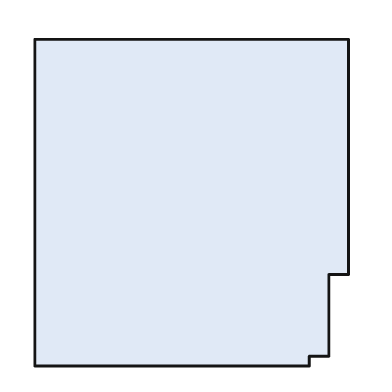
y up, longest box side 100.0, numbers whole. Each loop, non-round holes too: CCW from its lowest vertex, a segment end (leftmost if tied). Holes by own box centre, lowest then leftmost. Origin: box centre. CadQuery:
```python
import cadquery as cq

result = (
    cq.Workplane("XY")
    .moveTo(-48.0, -50.0)
    .lineTo(36.0, -50.0)
    .lineTo(36.0, -47.0)
    .lineTo(42.0, -47.0)
    .lineTo(42.0, -22.0)
    .lineTo(48.0, -22.0)
    .lineTo(48.0, 50.0)
    .lineTo(-48.0, 50.0)
    .close()
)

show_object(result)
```